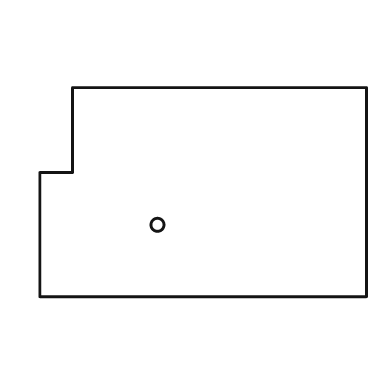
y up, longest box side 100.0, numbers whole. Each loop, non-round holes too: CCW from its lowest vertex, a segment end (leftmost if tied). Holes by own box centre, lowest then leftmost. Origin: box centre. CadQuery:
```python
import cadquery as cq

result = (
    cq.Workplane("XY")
    .moveTo(-50.0, -32.0)
    .lineTo(50.0, -32.0)
    .lineTo(50.0, 32.0)
    .lineTo(-40.0, 32.0)
    .lineTo(-40.0, 6.0)
    .lineTo(-50.0, 6.0)
    .close()
    .moveTo(-14.0, -10.0)
    .circle(2.0)
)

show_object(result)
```